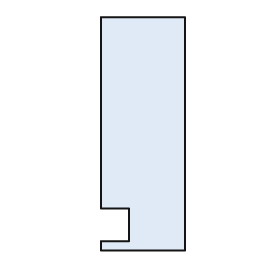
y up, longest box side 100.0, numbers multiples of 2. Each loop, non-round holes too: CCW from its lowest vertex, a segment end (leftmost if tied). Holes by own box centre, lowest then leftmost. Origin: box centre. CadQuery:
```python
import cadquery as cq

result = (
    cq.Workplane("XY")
    .moveTo(-18.0, -50.0)
    .lineTo(18.0, -50.0)
    .lineTo(18.0, 50.0)
    .lineTo(-18.0, 50.0)
    .lineTo(-18.0, -32.0)
    .lineTo(-6.0, -32.0)
    .lineTo(-6.0, -46.0)
    .lineTo(-18.0, -46.0)
    .close()
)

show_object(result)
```